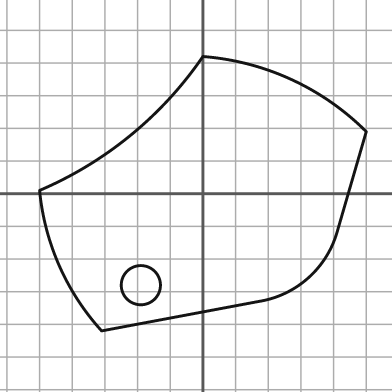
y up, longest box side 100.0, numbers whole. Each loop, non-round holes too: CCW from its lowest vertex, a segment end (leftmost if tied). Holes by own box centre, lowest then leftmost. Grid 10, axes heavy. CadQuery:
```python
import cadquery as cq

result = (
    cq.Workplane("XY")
    .moveTo(-31.0, -42.0)
    .lineTo(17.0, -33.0)
    .threePointArc((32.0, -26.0), (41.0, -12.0))
    .lineTo(50.0, 19.0)
    .threePointArc((27.0, 35.0), (0.0, 42.0))
    .threePointArc((-22.0, 18.0), (-50.0, 1.0))
    .threePointArc((-44.0, -22.0), (-31.0, -42.0))
    .close()
    .moveTo(-19.0, -28.0)
    .circle(6.0)
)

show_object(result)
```